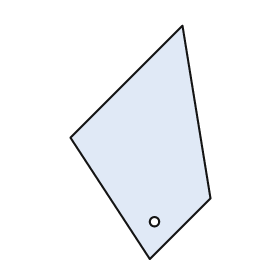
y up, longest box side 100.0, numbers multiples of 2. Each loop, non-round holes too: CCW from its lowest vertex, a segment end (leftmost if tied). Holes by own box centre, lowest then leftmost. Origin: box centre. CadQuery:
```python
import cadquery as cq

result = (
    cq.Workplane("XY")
    .moveTo(4.0, -50.0)
    .lineTo(30.0, -24.0)
    .lineTo(18.0, 50.0)
    .lineTo(-30.0, 2.0)
    .close()
    .moveTo(6.0, -34.0)
    .circle(2.0)
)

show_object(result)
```